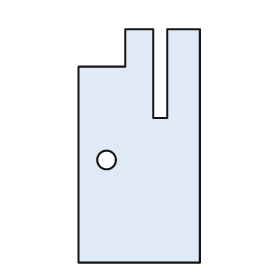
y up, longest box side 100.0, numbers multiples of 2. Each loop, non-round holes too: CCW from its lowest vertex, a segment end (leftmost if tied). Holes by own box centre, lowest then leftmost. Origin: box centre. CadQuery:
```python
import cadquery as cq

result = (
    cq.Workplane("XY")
    .moveTo(-26.0, -50.0)
    .lineTo(26.0, -50.0)
    .lineTo(26.0, 50.0)
    .lineTo(12.0, 50.0)
    .lineTo(12.0, 12.0)
    .lineTo(6.0, 12.0)
    .lineTo(6.0, 50.0)
    .lineTo(-6.0, 50.0)
    .lineTo(-6.0, 34.0)
    .lineTo(-26.0, 34.0)
    .close()
    .moveTo(-14.0, -6.0)
    .circle(4.0)
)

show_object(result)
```